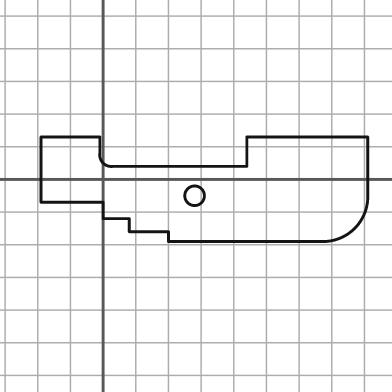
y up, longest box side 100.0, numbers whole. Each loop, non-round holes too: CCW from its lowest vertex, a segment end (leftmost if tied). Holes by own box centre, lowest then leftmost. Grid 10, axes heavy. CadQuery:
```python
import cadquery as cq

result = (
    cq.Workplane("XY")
    .moveTo(20.0, -19.0)
    .lineTo(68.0, -19.0)
    .threePointArc((77.0, -15.0), (81.0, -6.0))
    .lineTo(81.0, 13.0)
    .lineTo(44.0, 13.0)
    .lineTo(44.0, 4.0)
    .lineTo(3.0, 4.0)
    .threePointArc((0.0, 5.0), (-1.0, 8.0))
    .lineTo(-1.0, 13.0)
    .lineTo(-19.0, 13.0)
    .lineTo(-19.0, -7.0)
    .lineTo(0.0, -7.0)
    .lineTo(0.0, -12.0)
    .lineTo(8.0, -12.0)
    .lineTo(8.0, -16.0)
    .lineTo(20.0, -16.0)
    .close()
    .moveTo(28.0, -5.0)
    .circle(3.0)
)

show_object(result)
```